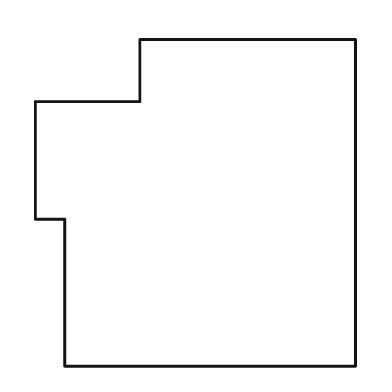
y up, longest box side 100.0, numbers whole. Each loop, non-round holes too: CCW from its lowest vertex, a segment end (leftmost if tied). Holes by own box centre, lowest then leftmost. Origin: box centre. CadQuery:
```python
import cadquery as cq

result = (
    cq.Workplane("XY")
    .moveTo(-40.0, -50.0)
    .lineTo(49.0, -50.0)
    .lineTo(49.0, 50.0)
    .lineTo(-17.0, 50.0)
    .lineTo(-17.0, 31.0)
    .lineTo(-49.0, 31.0)
    .lineTo(-49.0, -5.0)
    .lineTo(-40.0, -5.0)
    .close()
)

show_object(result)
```